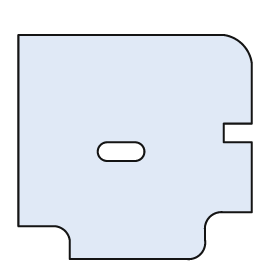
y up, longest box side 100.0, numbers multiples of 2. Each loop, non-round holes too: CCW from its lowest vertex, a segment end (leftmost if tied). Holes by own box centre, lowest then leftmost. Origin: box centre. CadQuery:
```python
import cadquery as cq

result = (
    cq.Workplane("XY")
    .moveTo(-28.0, -48.0)
    .lineTo(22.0, -48.0)
    .threePointArc((28.0, -46.0), (30.0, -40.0))
    .lineTo(30.0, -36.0)
    .threePointArc((32.0, -30.0), (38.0, -28.0))
    .lineTo(50.0, -28.0)
    .lineTo(50.0, 2.0)
    .lineTo(38.0, 2.0)
    .lineTo(38.0, 10.0)
    .lineTo(50.0, 10.0)
    .lineTo(50.0, 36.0)
    .threePointArc((46.0, 44.0), (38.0, 48.0))
    .lineTo(-50.0, 48.0)
    .lineTo(-50.0, -34.0)
    .lineTo(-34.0, -34.0)
    .threePointArc((-30.0, -36.0), (-28.0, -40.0))
    .close()
    .moveTo(-12.0, -6.0)
    .lineTo(0.0, -6.0)
    .threePointArc((4.0, -2.0), (0.0, 2.0))
    .lineTo(-12.0, 2.0)
    .threePointArc((-16.0, -2.0), (-12.0, -6.0))
    .close()
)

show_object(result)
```